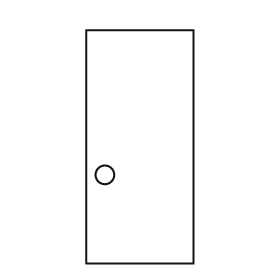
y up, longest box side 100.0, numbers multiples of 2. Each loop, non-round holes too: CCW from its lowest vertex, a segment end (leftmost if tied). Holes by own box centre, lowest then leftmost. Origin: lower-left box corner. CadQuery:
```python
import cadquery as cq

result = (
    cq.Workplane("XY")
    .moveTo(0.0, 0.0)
    .lineTo(46.0, 0.0)
    .lineTo(46.0, 100.0)
    .lineTo(0.0, 100.0)
    .close()
    .moveTo(8.0, 38.0)
    .circle(4.0)
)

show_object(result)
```